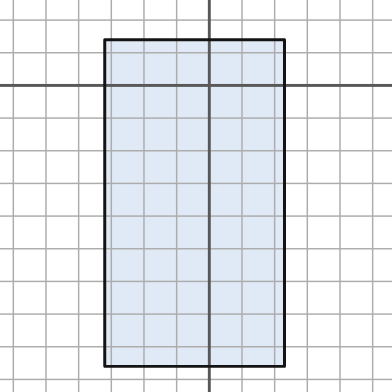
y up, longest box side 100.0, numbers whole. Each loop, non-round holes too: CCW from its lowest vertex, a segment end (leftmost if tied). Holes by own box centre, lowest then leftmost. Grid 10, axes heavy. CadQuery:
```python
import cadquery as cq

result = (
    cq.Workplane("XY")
    .moveTo(-32.0, -86.0)
    .lineTo(23.0, -86.0)
    .lineTo(23.0, 14.0)
    .lineTo(-32.0, 14.0)
    .close()
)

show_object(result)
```